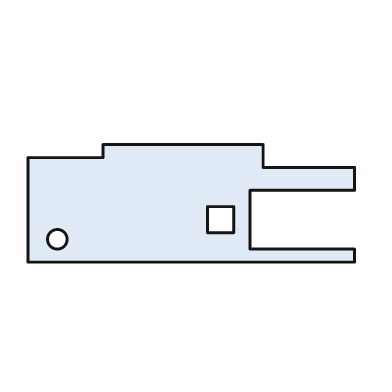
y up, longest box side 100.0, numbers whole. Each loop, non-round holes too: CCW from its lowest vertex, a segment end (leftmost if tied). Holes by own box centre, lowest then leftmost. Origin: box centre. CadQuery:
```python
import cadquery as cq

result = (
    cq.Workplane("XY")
    .moveTo(-50.0, -18.0)
    .lineTo(50.0, -18.0)
    .lineTo(50.0, -14.0)
    .lineTo(18.0, -14.0)
    .lineTo(18.0, 4.0)
    .lineTo(50.0, 4.0)
    .lineTo(50.0, 11.0)
    .lineTo(22.0, 11.0)
    .lineTo(22.0, 18.0)
    .lineTo(-27.0, 18.0)
    .lineTo(-27.0, 14.0)
    .lineTo(-50.0, 14.0)
    .close()
    .moveTo(-41.0, -11.0)
    .circle(3.0)
    .moveTo(5.0, -9.0)
    .lineTo(13.0, -9.0)
    .lineTo(13.0, -1.0)
    .lineTo(5.0, -1.0)
    .close()
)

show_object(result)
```